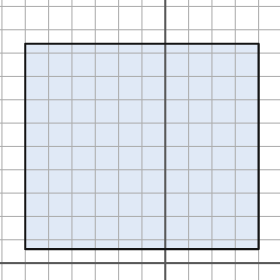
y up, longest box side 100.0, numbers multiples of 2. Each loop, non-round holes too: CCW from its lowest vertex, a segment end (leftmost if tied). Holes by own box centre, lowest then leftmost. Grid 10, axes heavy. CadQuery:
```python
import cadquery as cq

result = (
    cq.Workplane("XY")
    .moveTo(-60.0, 6.0)
    .lineTo(40.0, 6.0)
    .lineTo(40.0, 94.0)
    .lineTo(-60.0, 94.0)
    .close()
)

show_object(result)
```